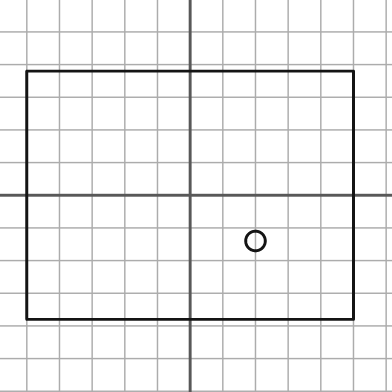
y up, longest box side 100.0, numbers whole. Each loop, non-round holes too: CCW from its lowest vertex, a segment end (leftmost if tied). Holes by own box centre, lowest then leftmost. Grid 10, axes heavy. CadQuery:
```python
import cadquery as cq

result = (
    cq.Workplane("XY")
    .moveTo(-50.0, -38.0)
    .lineTo(50.0, -38.0)
    .lineTo(50.0, 38.0)
    .lineTo(-50.0, 38.0)
    .close()
    .moveTo(20.0, -14.0)
    .circle(3.0)
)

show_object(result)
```